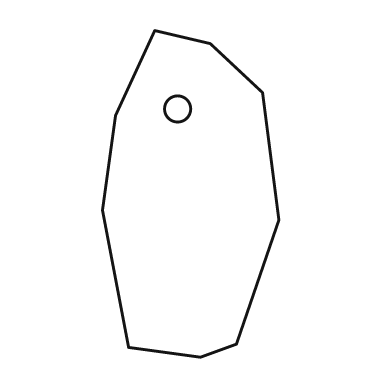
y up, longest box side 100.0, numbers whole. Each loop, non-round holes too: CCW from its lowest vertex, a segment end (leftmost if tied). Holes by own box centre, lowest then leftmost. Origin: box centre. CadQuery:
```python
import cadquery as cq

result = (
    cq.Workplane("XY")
    .moveTo(3.0, -50.0)
    .lineTo(14.0, -46.0)
    .lineTo(27.0, -8.0)
    .lineTo(22.0, 31.0)
    .lineTo(6.0, 46.0)
    .lineTo(-11.0, 50.0)
    .lineTo(-23.0, 24.0)
    .lineTo(-27.0, -5.0)
    .lineTo(-19.0, -47.0)
    .close()
    .moveTo(-4.0, 26.0)
    .circle(4.0)
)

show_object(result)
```